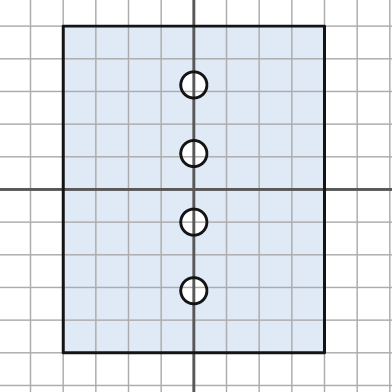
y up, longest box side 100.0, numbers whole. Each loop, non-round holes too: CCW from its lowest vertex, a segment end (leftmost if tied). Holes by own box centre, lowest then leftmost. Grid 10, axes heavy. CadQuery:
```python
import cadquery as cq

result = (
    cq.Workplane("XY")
    .moveTo(-40.0, -50.0)
    .lineTo(40.0, -50.0)
    .lineTo(40.0, 50.0)
    .lineTo(-40.0, 50.0)
    .close()
    .moveTo(0.0, -31.0)
    .circle(4.0)
    .moveTo(0.0, -10.0)
    .circle(4.0)
    .moveTo(0.0, 11.0)
    .circle(4.0)
    .moveTo(0.0, 32.0)
    .circle(4.0)
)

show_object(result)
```